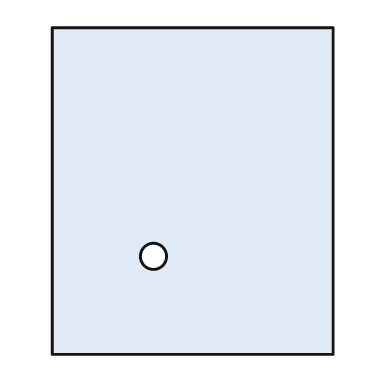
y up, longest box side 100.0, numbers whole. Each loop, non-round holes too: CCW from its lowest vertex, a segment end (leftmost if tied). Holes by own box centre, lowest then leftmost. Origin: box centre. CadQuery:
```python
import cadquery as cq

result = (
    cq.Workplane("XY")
    .moveTo(-43.0, -50.0)
    .lineTo(43.0, -50.0)
    .lineTo(43.0, 50.0)
    .lineTo(-43.0, 50.0)
    .close()
    .moveTo(-12.0, -20.0)
    .circle(4.0)
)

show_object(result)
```